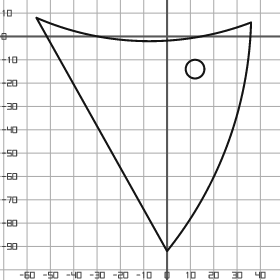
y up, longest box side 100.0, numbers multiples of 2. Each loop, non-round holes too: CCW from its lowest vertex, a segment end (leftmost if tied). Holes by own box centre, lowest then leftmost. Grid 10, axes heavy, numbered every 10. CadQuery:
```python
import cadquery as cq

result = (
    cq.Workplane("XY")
    .moveTo(0.0, -92.0)
    .threePointArc((26.0, -46.0), (36.0, 6.0))
    .threePointArc((-10.0, -2.0), (-56.0, 8.0))
    .close()
    .moveTo(12.0, -14.0)
    .circle(4.0)
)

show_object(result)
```